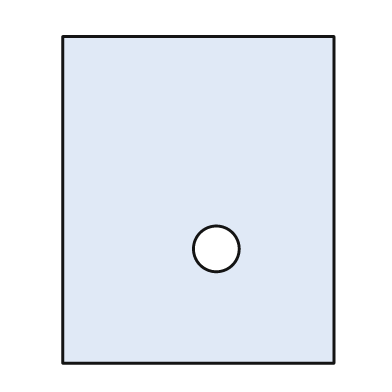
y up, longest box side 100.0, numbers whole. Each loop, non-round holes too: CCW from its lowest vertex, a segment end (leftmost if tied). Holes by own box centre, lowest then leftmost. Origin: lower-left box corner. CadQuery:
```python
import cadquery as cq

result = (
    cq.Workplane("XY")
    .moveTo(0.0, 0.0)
    .lineTo(83.0, 0.0)
    .lineTo(83.0, 100.0)
    .lineTo(0.0, 100.0)
    .close()
    .moveTo(47.0, 35.0)
    .circle(7.0)
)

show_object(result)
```